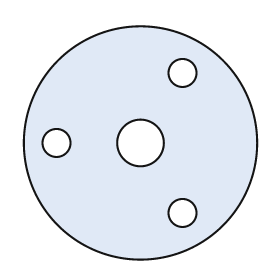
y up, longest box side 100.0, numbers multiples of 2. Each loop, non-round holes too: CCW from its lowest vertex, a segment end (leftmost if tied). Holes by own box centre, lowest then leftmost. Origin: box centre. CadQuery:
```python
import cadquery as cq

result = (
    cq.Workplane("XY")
    .moveTo(0.0, 0.0)
    .circle(50.0)
    .moveTo(18.0, -30.0)
    .circle(6.0)
    .moveTo(-36.0, 0.0)
    .circle(6.0)
    .moveTo(0.0, 0.0)
    .circle(10.0)
    .moveTo(18.0, 30.0)
    .circle(6.0)
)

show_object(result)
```